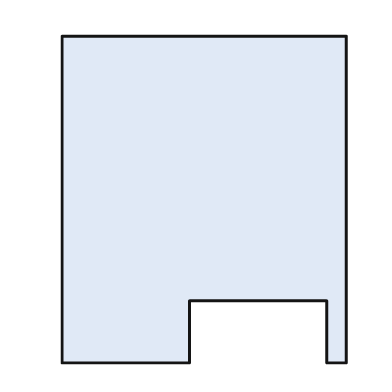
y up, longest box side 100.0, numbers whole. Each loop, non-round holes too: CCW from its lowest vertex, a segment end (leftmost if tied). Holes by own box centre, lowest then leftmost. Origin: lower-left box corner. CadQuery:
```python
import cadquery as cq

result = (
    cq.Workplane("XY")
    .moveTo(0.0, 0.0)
    .lineTo(39.0, 0.0)
    .lineTo(39.0, 19.0)
    .lineTo(81.0, 19.0)
    .lineTo(81.0, 0.0)
    .lineTo(87.0, 0.0)
    .lineTo(87.0, 100.0)
    .lineTo(0.0, 100.0)
    .close()
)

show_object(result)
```